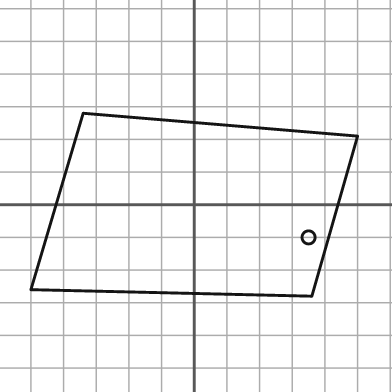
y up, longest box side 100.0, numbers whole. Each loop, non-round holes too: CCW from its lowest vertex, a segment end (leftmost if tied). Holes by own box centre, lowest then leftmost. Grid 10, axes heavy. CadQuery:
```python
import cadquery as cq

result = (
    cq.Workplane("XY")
    .moveTo(36.0, -28.0)
    .lineTo(50.0, 21.0)
    .lineTo(-34.0, 28.0)
    .lineTo(-50.0, -26.0)
    .close()
    .moveTo(35.0, -10.0)
    .circle(2.0)
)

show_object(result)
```